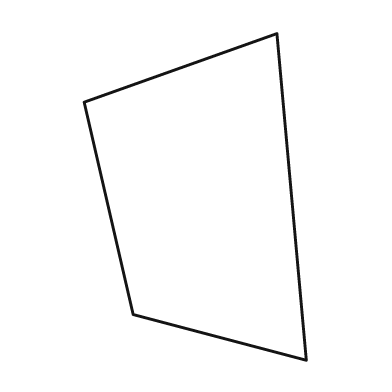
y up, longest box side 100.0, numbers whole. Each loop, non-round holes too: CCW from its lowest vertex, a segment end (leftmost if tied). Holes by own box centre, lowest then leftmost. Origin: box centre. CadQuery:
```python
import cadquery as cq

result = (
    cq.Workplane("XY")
    .moveTo(34.0, -50.0)
    .lineTo(25.0, 50.0)
    .lineTo(-34.0, 29.0)
    .lineTo(-19.0, -36.0)
    .close()
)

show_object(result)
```